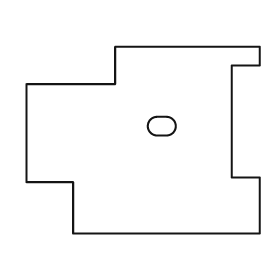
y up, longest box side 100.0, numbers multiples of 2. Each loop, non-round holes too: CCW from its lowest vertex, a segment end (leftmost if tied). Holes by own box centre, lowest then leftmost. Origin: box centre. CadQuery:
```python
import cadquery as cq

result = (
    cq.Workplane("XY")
    .moveTo(-30.0, -40.0)
    .lineTo(50.0, -40.0)
    .lineTo(50.0, -16.0)
    .lineTo(38.0, -16.0)
    .lineTo(38.0, 32.0)
    .lineTo(50.0, 32.0)
    .lineTo(50.0, 40.0)
    .lineTo(-12.0, 40.0)
    .lineTo(-12.0, 24.0)
    .lineTo(-50.0, 24.0)
    .lineTo(-50.0, -18.0)
    .lineTo(-30.0, -18.0)
    .close()
    .moveTo(6.0, 2.0)
    .lineTo(10.0, 2.0)
    .threePointArc((14.0, 6.0), (10.0, 10.0))
    .lineTo(6.0, 10.0)
    .threePointArc((2.0, 6.0), (6.0, 2.0))
    .close()
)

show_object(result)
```